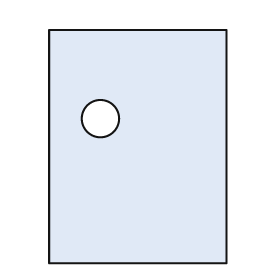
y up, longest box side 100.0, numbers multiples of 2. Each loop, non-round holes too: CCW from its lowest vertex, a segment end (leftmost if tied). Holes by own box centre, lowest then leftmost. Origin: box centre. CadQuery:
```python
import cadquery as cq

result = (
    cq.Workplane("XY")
    .moveTo(-38.0, -50.0)
    .lineTo(38.0, -50.0)
    .lineTo(38.0, 50.0)
    .lineTo(-38.0, 50.0)
    .close()
    .moveTo(-16.0, 12.0)
    .circle(8.0)
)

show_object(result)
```